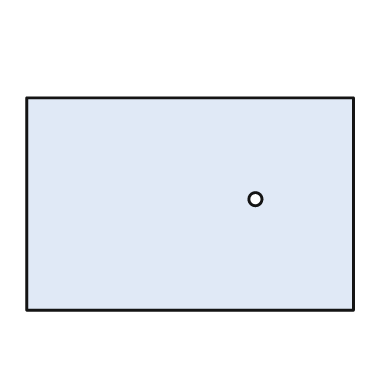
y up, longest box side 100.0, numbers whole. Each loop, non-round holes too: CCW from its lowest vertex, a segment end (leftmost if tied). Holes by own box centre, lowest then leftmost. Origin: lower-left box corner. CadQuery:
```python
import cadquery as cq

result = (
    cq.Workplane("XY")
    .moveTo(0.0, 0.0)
    .lineTo(100.0, 0.0)
    .lineTo(100.0, 65.0)
    .lineTo(0.0, 65.0)
    .close()
    .moveTo(70.0, 34.0)
    .circle(2.0)
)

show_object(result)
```